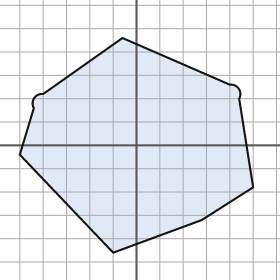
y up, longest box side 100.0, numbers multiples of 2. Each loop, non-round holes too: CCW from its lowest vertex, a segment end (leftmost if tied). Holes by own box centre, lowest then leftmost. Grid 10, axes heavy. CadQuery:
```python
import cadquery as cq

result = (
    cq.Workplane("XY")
    .moveTo(-10.0, -46.0)
    .lineTo(28.0, -32.0)
    .lineTo(50.0, -18.0)
    .lineTo(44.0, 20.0)
    .threePointArc((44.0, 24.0), (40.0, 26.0))
    .lineTo(-6.0, 46.0)
    .lineTo(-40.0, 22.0)
    .threePointArc((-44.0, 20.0), (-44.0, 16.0))
    .lineTo(-50.0, -4.0)
    .close()
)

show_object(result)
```